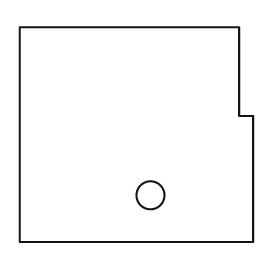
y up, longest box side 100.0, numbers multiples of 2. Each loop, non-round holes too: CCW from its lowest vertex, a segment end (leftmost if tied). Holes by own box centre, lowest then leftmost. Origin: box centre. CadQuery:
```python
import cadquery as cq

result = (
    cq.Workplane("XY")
    .moveTo(-50.0, -46.0)
    .lineTo(50.0, -46.0)
    .lineTo(50.0, 8.0)
    .lineTo(44.0, 8.0)
    .lineTo(44.0, 46.0)
    .lineTo(-50.0, 46.0)
    .close()
    .moveTo(6.0, -26.0)
    .circle(6.0)
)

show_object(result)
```